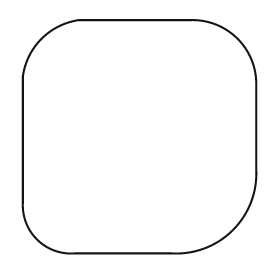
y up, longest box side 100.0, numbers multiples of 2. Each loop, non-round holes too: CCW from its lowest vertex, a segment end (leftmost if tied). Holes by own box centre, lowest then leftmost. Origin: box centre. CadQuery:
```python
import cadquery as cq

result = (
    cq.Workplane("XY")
    .moveTo(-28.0, -50.0)
    .lineTo(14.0, -50.0)
    .threePointArc((40.0, -40.0), (50.0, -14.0))
    .lineTo(50.0, 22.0)
    .threePointArc((42.0, 42.0), (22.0, 50.0))
    .lineTo(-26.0, 50.0)
    .threePointArc((-42.0, 42.0), (-50.0, 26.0))
    .lineTo(-50.0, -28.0)
    .threePointArc((-44.0, -44.0), (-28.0, -50.0))
    .close()
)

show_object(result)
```